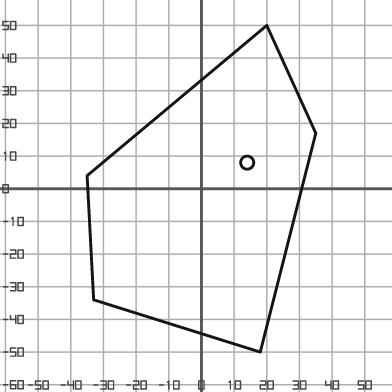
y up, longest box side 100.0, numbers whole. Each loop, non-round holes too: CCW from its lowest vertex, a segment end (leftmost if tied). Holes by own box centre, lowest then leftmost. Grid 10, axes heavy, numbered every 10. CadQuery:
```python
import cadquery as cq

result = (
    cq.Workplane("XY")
    .moveTo(18.0, -50.0)
    .lineTo(35.0, 17.0)
    .lineTo(20.0, 50.0)
    .lineTo(-35.0, 4.0)
    .lineTo(-33.0, -34.0)
    .close()
    .moveTo(14.0, 8.0)
    .circle(2.0)
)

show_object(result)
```